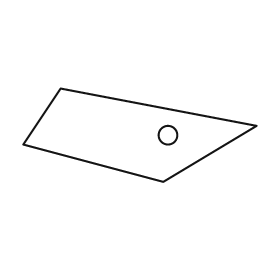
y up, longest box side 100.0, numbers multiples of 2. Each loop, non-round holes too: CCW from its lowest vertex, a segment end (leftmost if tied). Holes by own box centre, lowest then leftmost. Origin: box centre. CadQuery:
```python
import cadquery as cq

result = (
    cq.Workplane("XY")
    .moveTo(10.0, -20.0)
    .lineTo(50.0, 4.0)
    .lineTo(-34.0, 20.0)
    .lineTo(-50.0, -4.0)
    .close()
    .moveTo(12.0, 0.0)
    .circle(4.0)
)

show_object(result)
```